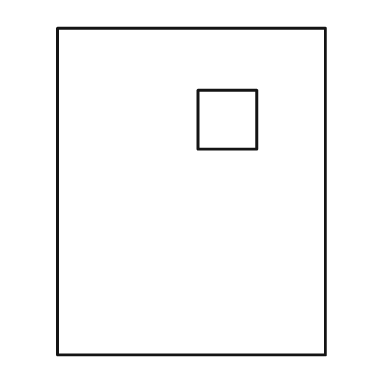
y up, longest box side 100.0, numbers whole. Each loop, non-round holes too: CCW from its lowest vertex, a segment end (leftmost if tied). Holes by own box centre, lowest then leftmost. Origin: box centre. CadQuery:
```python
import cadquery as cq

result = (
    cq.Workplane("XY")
    .moveTo(-41.0, -50.0)
    .lineTo(41.0, -50.0)
    .lineTo(41.0, 50.0)
    .lineTo(-41.0, 50.0)
    .close()
    .moveTo(2.0, 13.0)
    .lineTo(20.0, 13.0)
    .lineTo(20.0, 31.0)
    .lineTo(2.0, 31.0)
    .close()
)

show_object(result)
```